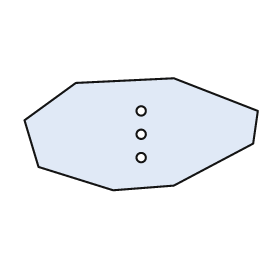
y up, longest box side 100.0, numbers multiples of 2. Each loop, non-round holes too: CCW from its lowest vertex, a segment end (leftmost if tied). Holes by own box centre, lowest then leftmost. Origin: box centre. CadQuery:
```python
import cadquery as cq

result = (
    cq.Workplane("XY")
    .moveTo(-12.0, -24.0)
    .lineTo(14.0, -22.0)
    .lineTo(48.0, -4.0)
    .lineTo(50.0, 10.0)
    .lineTo(14.0, 24.0)
    .lineTo(-28.0, 22.0)
    .lineTo(-50.0, 6.0)
    .lineTo(-44.0, -14.0)
    .close()
    .moveTo(0.0, -10.0)
    .circle(2.0)
    .moveTo(0.0, 0.0)
    .circle(2.0)
    .moveTo(0.0, 10.0)
    .circle(2.0)
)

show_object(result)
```